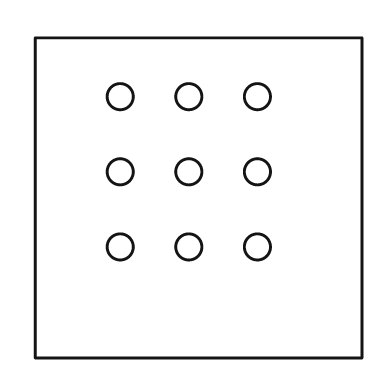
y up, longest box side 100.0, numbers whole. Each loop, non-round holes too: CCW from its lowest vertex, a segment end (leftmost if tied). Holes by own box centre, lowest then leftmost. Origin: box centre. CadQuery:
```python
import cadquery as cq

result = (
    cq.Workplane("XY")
    .moveTo(-50.0, -49.0)
    .lineTo(50.0, -49.0)
    .lineTo(50.0, 49.0)
    .lineTo(-50.0, 49.0)
    .close()
    .moveTo(-24.0, -15.0)
    .circle(4.0)
    .moveTo(-3.0, -15.0)
    .circle(4.0)
    .moveTo(18.0, -15.0)
    .circle(4.0)
    .moveTo(-24.0, 8.0)
    .circle(4.0)
    .moveTo(-3.0, 8.0)
    .circle(4.0)
    .moveTo(18.0, 8.0)
    .circle(4.0)
    .moveTo(-24.0, 31.0)
    .circle(4.0)
    .moveTo(-3.0, 31.0)
    .circle(4.0)
    .moveTo(18.0, 31.0)
    .circle(4.0)
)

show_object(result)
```